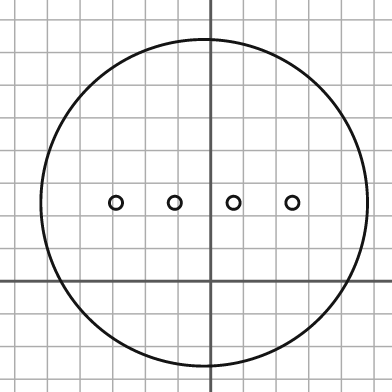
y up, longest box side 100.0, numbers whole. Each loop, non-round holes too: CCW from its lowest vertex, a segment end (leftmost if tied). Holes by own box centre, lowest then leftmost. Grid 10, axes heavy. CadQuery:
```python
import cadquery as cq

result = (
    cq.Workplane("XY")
    .moveTo(-2.0, 24.0)
    .circle(50.0)
    .moveTo(-29.0, 24.0)
    .circle(2.0)
    .moveTo(-11.0, 24.0)
    .circle(2.0)
    .moveTo(7.0, 24.0)
    .circle(2.0)
    .moveTo(25.0, 24.0)
    .circle(2.0)
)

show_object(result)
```